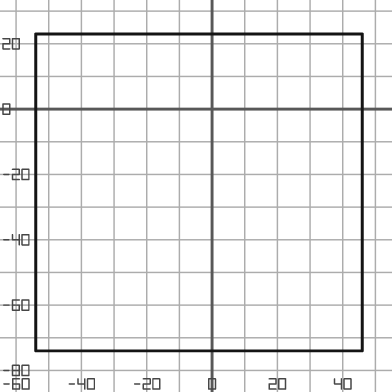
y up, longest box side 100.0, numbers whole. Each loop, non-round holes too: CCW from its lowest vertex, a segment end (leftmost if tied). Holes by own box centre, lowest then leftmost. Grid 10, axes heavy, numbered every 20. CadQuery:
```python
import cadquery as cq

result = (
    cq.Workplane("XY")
    .moveTo(-54.0, -74.0)
    .lineTo(46.0, -74.0)
    .lineTo(46.0, 23.0)
    .lineTo(-54.0, 23.0)
    .close()
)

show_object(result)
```